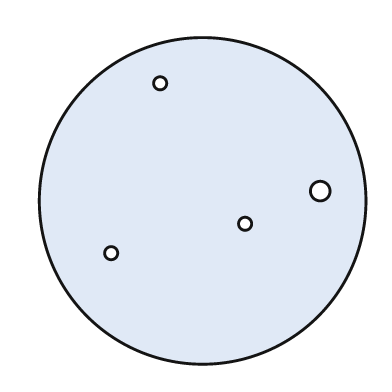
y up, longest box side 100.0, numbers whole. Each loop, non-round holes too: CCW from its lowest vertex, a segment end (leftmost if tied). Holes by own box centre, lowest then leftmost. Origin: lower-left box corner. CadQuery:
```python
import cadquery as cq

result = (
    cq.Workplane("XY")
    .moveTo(50.0, 50.0)
    .circle(50.0)
    .moveTo(22.0, 34.0)
    .circle(2.0)
    .moveTo(63.0, 43.0)
    .circle(2.0)
    .moveTo(86.0, 53.0)
    .circle(3.0)
    .moveTo(37.0, 86.0)
    .circle(2.0)
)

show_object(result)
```